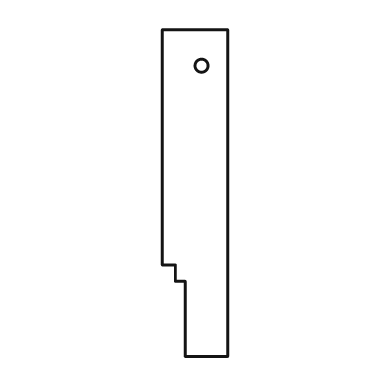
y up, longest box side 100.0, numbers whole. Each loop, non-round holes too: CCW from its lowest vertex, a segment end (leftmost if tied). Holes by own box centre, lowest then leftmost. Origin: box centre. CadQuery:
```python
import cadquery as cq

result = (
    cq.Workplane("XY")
    .moveTo(-3.0, -50.0)
    .lineTo(10.0, -50.0)
    .lineTo(10.0, 50.0)
    .lineTo(-10.0, 50.0)
    .lineTo(-10.0, -22.0)
    .lineTo(-6.0, -22.0)
    .lineTo(-6.0, -27.0)
    .lineTo(-3.0, -27.0)
    .close()
    .moveTo(2.0, 39.0)
    .circle(2.0)
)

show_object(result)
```